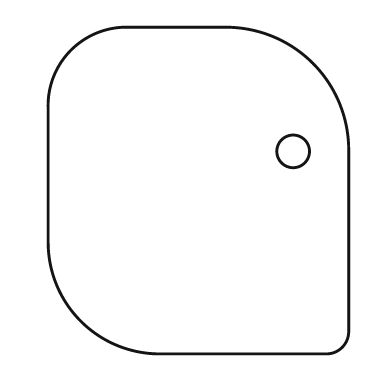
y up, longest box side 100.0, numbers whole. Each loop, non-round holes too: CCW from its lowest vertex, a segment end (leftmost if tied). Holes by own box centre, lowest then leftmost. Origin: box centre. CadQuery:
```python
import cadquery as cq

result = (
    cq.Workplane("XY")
    .moveTo(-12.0, -50.0)
    .lineTo(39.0, -50.0)
    .threePointArc((44.0, -48.0), (46.0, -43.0))
    .lineTo(46.0, 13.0)
    .threePointArc((35.0, 39.0), (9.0, 50.0))
    .lineTo(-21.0, 50.0)
    .threePointArc((-39.0, 43.0), (-46.0, 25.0))
    .lineTo(-46.0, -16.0)
    .threePointArc((-36.0, -40.0), (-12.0, -50.0))
    .close()
    .moveTo(29.0, 12.0)
    .circle(5.0)
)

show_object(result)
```